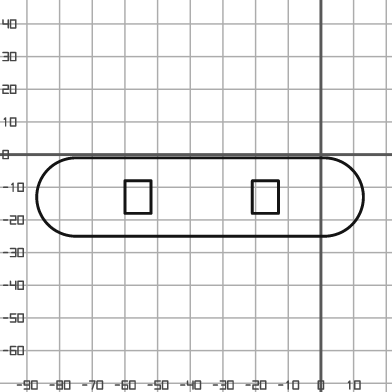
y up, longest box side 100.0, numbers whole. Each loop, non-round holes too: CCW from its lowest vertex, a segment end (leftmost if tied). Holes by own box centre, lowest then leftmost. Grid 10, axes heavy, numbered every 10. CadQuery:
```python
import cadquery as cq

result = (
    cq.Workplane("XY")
    .moveTo(-75.0, -25.0)
    .lineTo(1.0, -25.0)
    .threePointArc((13.0, -13.0), (1.0, -1.0))
    .lineTo(-75.0, -1.0)
    .threePointArc((-87.0, -13.0), (-75.0, -25.0))
    .close()
    .moveTo(-60.0, -18.0)
    .lineTo(-52.0, -18.0)
    .lineTo(-52.0, -8.0)
    .lineTo(-60.0, -8.0)
    .close()
    .moveTo(-21.0, -18.0)
    .lineTo(-13.0, -18.0)
    .lineTo(-13.0, -8.0)
    .lineTo(-21.0, -8.0)
    .close()
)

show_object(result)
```